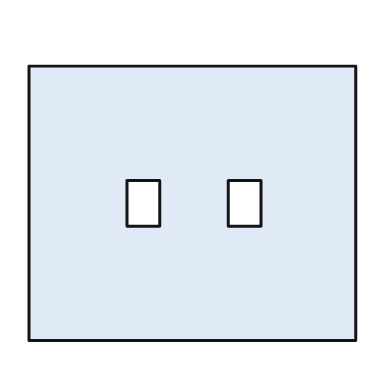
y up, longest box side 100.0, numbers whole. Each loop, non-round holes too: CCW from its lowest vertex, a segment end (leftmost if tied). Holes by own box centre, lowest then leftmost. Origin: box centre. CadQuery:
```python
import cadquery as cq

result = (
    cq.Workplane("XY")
    .moveTo(-50.0, -42.0)
    .lineTo(50.0, -42.0)
    .lineTo(50.0, 42.0)
    .lineTo(-50.0, 42.0)
    .close()
    .moveTo(-20.0, -7.0)
    .lineTo(-10.0, -7.0)
    .lineTo(-10.0, 7.0)
    .lineTo(-20.0, 7.0)
    .close()
    .moveTo(11.0, -7.0)
    .lineTo(21.0, -7.0)
    .lineTo(21.0, 7.0)
    .lineTo(11.0, 7.0)
    .close()
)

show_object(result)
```